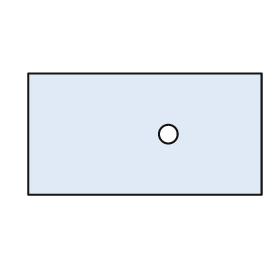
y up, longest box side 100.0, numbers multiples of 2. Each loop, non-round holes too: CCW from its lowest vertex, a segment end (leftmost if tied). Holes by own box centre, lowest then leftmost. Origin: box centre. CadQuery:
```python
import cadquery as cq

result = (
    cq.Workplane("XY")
    .moveTo(-50.0, -26.0)
    .lineTo(50.0, -26.0)
    .lineTo(50.0, 26.0)
    .lineTo(-50.0, 26.0)
    .close()
    .moveTo(10.0, 0.0)
    .circle(4.0)
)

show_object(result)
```